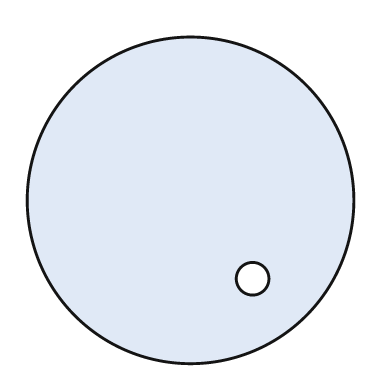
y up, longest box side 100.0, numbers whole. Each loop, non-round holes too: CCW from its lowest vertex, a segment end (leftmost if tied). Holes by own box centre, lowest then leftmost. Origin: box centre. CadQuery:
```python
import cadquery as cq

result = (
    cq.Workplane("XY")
    .moveTo(0.0, 0.0)
    .circle(50.0)
    .moveTo(19.0, -24.0)
    .circle(5.0)
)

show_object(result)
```